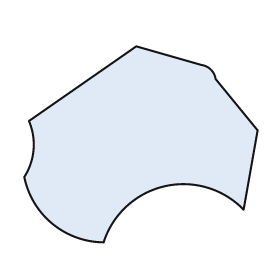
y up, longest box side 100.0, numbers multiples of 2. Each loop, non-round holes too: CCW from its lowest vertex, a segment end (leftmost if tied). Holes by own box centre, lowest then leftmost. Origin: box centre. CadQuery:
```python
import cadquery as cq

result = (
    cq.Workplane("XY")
    .moveTo(-16.0, -42.0)
    .threePointArc((10.0, -18.0), (44.0, -28.0))
    .lineTo(50.0, 6.0)
    .lineTo(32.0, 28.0)
    .threePointArc((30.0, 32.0), (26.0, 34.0))
    .lineTo(-2.0, 42.0)
    .lineTo(-48.0, 10.0)
    .threePointArc((-46.0, -2.0), (-50.0, -14.0))
    .threePointArc((-38.0, -34.0), (-16.0, -42.0))
    .close()
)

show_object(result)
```